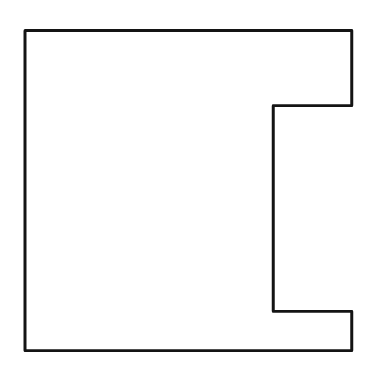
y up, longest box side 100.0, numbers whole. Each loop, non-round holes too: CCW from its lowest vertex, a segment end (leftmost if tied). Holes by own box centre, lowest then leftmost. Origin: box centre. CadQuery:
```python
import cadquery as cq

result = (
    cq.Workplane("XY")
    .moveTo(-50.0, -49.0)
    .lineTo(50.0, -49.0)
    .lineTo(50.0, -37.0)
    .lineTo(26.0, -37.0)
    .lineTo(26.0, 26.0)
    .lineTo(50.0, 26.0)
    .lineTo(50.0, 49.0)
    .lineTo(-50.0, 49.0)
    .close()
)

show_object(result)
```